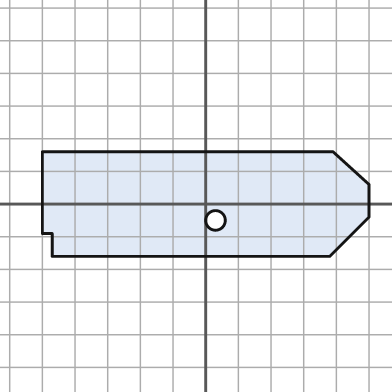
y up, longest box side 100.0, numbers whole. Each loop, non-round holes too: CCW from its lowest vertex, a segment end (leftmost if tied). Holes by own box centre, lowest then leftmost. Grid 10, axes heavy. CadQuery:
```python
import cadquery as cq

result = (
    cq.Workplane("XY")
    .moveTo(-47.0, -16.0)
    .lineTo(38.0, -16.0)
    .lineTo(50.0, -4.0)
    .lineTo(50.0, 6.0)
    .lineTo(39.0, 16.0)
    .lineTo(-50.0, 16.0)
    .lineTo(-50.0, -9.0)
    .lineTo(-47.0, -9.0)
    .close()
    .moveTo(3.0, -5.0)
    .circle(3.0)
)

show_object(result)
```